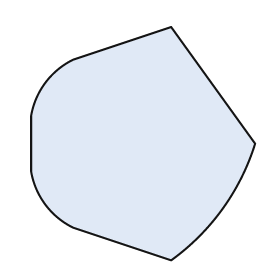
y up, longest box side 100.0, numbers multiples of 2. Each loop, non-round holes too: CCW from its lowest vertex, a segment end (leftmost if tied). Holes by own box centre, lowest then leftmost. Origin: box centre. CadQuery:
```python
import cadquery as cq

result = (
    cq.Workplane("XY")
    .moveTo(12.0, -50.0)
    .threePointArc((34.0, -28.0), (48.0, 0.0))
    .lineTo(12.0, 50.0)
    .lineTo(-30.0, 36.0)
    .threePointArc((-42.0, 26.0), (-48.0, 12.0))
    .lineTo(-48.0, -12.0)
    .threePointArc((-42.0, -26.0), (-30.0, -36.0))
    .close()
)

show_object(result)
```